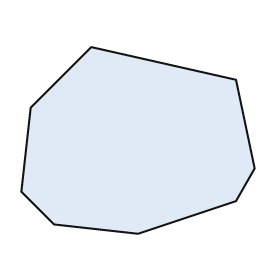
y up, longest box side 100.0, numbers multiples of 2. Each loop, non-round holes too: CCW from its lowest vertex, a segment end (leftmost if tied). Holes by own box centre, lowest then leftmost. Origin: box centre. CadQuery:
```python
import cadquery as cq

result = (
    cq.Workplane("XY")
    .moveTo(0.0, -40.0)
    .lineTo(42.0, -26.0)
    .lineTo(50.0, -12.0)
    .lineTo(42.0, 26.0)
    .lineTo(-20.0, 40.0)
    .lineTo(-46.0, 14.0)
    .lineTo(-50.0, -22.0)
    .lineTo(-36.0, -36.0)
    .close()
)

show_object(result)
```